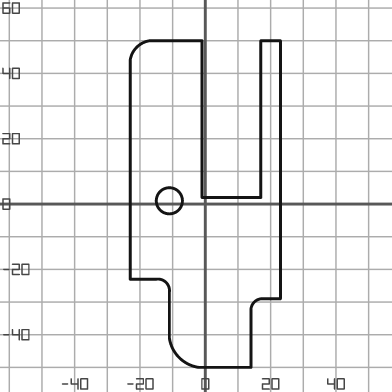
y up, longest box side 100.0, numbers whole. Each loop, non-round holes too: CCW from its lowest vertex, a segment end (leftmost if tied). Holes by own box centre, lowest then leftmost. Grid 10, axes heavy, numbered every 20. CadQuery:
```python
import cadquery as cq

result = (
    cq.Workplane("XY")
    .moveTo(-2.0, -50.0)
    .lineTo(14.0, -50.0)
    .lineTo(14.0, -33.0)
    .threePointArc((15.0, -30.0), (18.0, -29.0))
    .lineTo(23.0, -29.0)
    .lineTo(23.0, 50.0)
    .lineTo(17.0, 50.0)
    .lineTo(17.0, 2.0)
    .lineTo(-1.0, 2.0)
    .lineTo(-1.0, 50.0)
    .lineTo(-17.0, 50.0)
    .threePointArc((-21.0, 48.0), (-23.0, 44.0))
    .lineTo(-23.0, -23.0)
    .lineTo(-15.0, -23.0)
    .threePointArc((-12.0, -24.0), (-11.0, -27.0))
    .lineTo(-11.0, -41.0)
    .threePointArc((-8.0, -47.0), (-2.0, -50.0))
    .close()
    .moveTo(-11.0, 1.0)
    .circle(4.0)
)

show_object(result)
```